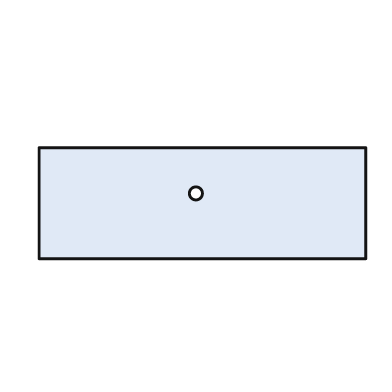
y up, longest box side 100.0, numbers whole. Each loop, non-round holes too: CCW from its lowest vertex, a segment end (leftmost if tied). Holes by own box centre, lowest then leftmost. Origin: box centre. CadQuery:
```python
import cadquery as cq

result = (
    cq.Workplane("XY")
    .moveTo(-50.0, -17.0)
    .lineTo(50.0, -17.0)
    .lineTo(50.0, 17.0)
    .lineTo(-50.0, 17.0)
    .close()
    .moveTo(-2.0, 3.0)
    .circle(2.0)
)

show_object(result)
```